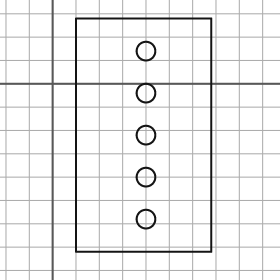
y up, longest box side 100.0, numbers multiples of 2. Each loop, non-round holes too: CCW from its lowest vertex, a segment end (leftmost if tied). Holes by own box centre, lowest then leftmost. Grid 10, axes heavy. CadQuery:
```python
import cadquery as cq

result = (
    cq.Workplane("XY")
    .moveTo(10.0, -72.0)
    .lineTo(68.0, -72.0)
    .lineTo(68.0, 28.0)
    .lineTo(10.0, 28.0)
    .close()
    .moveTo(40.0, -58.0)
    .circle(4.0)
    .moveTo(40.0, -40.0)
    .circle(4.0)
    .moveTo(40.0, -22.0)
    .circle(4.0)
    .moveTo(40.0, -4.0)
    .circle(4.0)
    .moveTo(40.0, 14.0)
    .circle(4.0)
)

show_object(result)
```